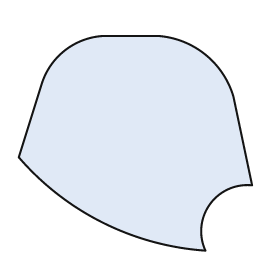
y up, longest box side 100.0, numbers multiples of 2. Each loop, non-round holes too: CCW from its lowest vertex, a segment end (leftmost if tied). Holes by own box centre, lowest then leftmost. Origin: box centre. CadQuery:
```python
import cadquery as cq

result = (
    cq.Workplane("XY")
    .moveTo(30.0, -46.0)
    .threePointArc((32.0, -26.0), (50.0, -18.0))
    .lineTo(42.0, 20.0)
    .threePointArc((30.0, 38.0), (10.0, 46.0))
    .lineTo(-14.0, 46.0)
    .threePointArc((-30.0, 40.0), (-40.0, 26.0))
    .lineTo(-50.0, -6.0)
    .threePointArc((-14.0, -34.0), (30.0, -46.0))
    .close()
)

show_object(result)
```